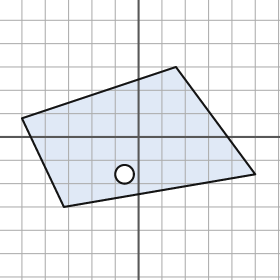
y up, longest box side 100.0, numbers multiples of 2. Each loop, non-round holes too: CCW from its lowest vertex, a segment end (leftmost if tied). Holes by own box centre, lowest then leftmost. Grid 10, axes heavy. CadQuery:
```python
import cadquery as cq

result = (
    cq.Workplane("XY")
    .moveTo(-32.0, -30.0)
    .lineTo(50.0, -16.0)
    .lineTo(16.0, 30.0)
    .lineTo(-50.0, 8.0)
    .close()
    .moveTo(-6.0, -16.0)
    .circle(4.0)
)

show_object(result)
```